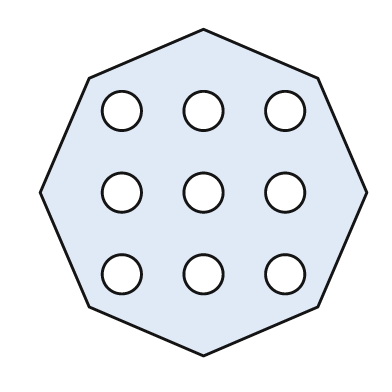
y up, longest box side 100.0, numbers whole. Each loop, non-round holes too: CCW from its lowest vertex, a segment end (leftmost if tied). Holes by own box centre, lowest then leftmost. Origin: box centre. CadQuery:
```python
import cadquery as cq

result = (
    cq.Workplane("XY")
    .moveTo(0.0, -50.0)
    .lineTo(35.0, -35.0)
    .lineTo(50.0, 0.0)
    .lineTo(35.0, 35.0)
    .lineTo(0.0, 50.0)
    .lineTo(-35.0, 35.0)
    .lineTo(-50.0, 0.0)
    .lineTo(-35.0, -35.0)
    .close()
    .moveTo(-25.0, -25.0)
    .circle(6.0)
    .moveTo(0.0, -25.0)
    .circle(6.0)
    .moveTo(25.0, -25.0)
    .circle(6.0)
    .moveTo(-25.0, 0.0)
    .circle(6.0)
    .moveTo(0.0, 0.0)
    .circle(6.0)
    .moveTo(25.0, 0.0)
    .circle(6.0)
    .moveTo(-25.0, 25.0)
    .circle(6.0)
    .moveTo(0.0, 25.0)
    .circle(6.0)
    .moveTo(25.0, 25.0)
    .circle(6.0)
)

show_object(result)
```